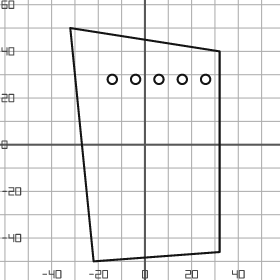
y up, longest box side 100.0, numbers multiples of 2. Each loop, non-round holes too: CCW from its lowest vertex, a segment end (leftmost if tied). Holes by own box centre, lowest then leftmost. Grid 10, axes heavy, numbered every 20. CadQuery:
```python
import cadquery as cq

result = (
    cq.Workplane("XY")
    .moveTo(-22.0, -50.0)
    .lineTo(32.0, -46.0)
    .lineTo(32.0, 40.0)
    .lineTo(-32.0, 50.0)
    .close()
    .moveTo(-14.0, 28.0)
    .circle(2.0)
    .moveTo(-4.0, 28.0)
    .circle(2.0)
    .moveTo(6.0, 28.0)
    .circle(2.0)
    .moveTo(16.0, 28.0)
    .circle(2.0)
    .moveTo(26.0, 28.0)
    .circle(2.0)
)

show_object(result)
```